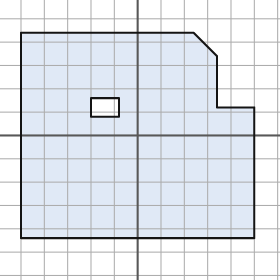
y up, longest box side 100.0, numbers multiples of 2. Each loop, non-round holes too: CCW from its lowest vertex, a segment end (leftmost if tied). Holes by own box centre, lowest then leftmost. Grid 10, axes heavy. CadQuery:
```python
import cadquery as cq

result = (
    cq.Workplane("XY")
    .moveTo(-50.0, -44.0)
    .lineTo(50.0, -44.0)
    .lineTo(50.0, 12.0)
    .lineTo(34.0, 12.0)
    .lineTo(34.0, 34.0)
    .lineTo(24.0, 44.0)
    .lineTo(-50.0, 44.0)
    .close()
    .moveTo(-20.0, 8.0)
    .lineTo(-8.0, 8.0)
    .lineTo(-8.0, 16.0)
    .lineTo(-20.0, 16.0)
    .close()
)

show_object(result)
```